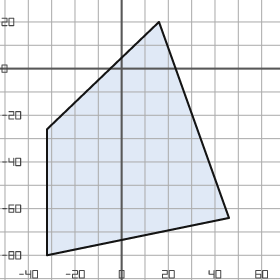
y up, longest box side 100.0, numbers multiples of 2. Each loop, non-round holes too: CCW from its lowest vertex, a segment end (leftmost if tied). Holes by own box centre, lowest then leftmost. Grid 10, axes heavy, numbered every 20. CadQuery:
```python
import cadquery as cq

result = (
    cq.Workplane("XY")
    .moveTo(-32.0, -80.0)
    .lineTo(46.0, -64.0)
    .lineTo(16.0, 20.0)
    .lineTo(-32.0, -26.0)
    .close()
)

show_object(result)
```